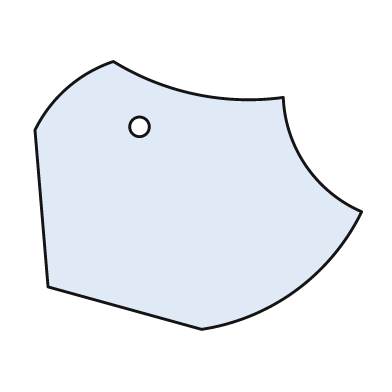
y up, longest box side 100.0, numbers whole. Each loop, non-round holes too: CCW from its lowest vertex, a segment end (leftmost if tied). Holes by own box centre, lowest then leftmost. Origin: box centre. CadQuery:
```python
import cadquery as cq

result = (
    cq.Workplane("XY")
    .moveTo(1.0, -41.0)
    .threePointArc((30.0, -29.0), (50.0, -5.0))
    .threePointArc((33.0, 9.0), (26.0, 30.0))
    .threePointArc((-1.0, 31.0), (-26.0, 41.0))
    .threePointArc((-40.0, 33.0), (-50.0, 20.0))
    .lineTo(-46.0, -28.0)
    .close()
    .moveTo(-18.0, 21.0)
    .circle(3.0)
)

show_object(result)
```